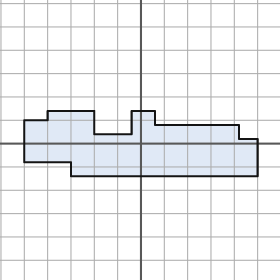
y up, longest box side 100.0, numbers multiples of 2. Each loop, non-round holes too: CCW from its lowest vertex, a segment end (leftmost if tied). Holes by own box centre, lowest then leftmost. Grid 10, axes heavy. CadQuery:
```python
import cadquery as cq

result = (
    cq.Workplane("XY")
    .moveTo(-30.0, -14.0)
    .lineTo(50.0, -14.0)
    .lineTo(50.0, 2.0)
    .lineTo(42.0, 2.0)
    .lineTo(42.0, 8.0)
    .lineTo(6.0, 8.0)
    .lineTo(6.0, 14.0)
    .lineTo(-4.0, 14.0)
    .lineTo(-4.0, 4.0)
    .lineTo(-20.0, 4.0)
    .lineTo(-20.0, 14.0)
    .lineTo(-40.0, 14.0)
    .lineTo(-40.0, 10.0)
    .lineTo(-50.0, 10.0)
    .lineTo(-50.0, -8.0)
    .lineTo(-30.0, -8.0)
    .close()
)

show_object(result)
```